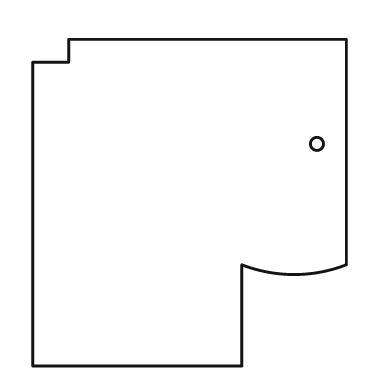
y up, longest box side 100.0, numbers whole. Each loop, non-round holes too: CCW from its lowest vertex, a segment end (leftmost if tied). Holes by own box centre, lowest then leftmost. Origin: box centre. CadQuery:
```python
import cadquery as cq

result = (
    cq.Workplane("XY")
    .moveTo(-48.0, -50.0)
    .lineTo(16.0, -50.0)
    .lineTo(16.0, -19.0)
    .threePointArc((32.0, -22.0), (48.0, -19.0))
    .lineTo(48.0, 50.0)
    .lineTo(-37.0, 50.0)
    .lineTo(-37.0, 43.0)
    .lineTo(-48.0, 43.0)
    .close()
    .moveTo(39.0, 18.0)
    .circle(2.0)
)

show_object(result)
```